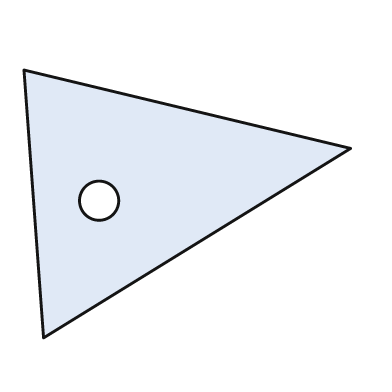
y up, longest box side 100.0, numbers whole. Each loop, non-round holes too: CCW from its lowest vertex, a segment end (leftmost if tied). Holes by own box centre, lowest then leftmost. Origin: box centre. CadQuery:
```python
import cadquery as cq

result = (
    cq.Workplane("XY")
    .moveTo(-44.0, -41.0)
    .lineTo(50.0, 17.0)
    .lineTo(-50.0, 41.0)
    .close()
    .moveTo(-27.0, 1.0)
    .circle(6.0)
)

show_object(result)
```